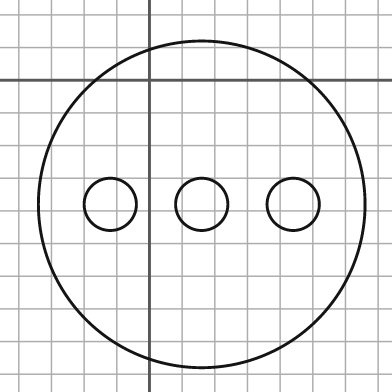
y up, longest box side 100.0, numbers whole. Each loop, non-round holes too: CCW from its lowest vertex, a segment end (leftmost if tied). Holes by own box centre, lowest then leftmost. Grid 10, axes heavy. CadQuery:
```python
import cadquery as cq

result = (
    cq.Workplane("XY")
    .moveTo(16.0, -38.0)
    .circle(50.0)
    .moveTo(-12.0, -38.0)
    .circle(8.0)
    .moveTo(16.0, -38.0)
    .circle(8.0)
    .moveTo(44.0, -38.0)
    .circle(8.0)
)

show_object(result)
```